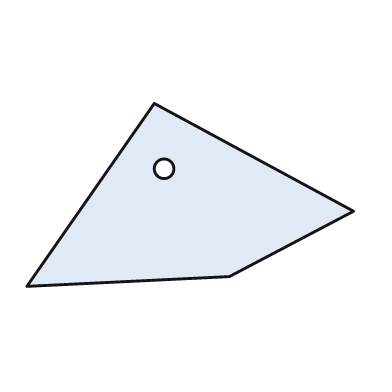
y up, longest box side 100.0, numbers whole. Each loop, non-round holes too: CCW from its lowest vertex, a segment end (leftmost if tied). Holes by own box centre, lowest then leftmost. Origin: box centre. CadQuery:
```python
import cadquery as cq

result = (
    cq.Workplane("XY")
    .moveTo(-50.0, -28.0)
    .lineTo(12.0, -25.0)
    .lineTo(50.0, -5.0)
    .lineTo(-11.0, 28.0)
    .close()
    .moveTo(-8.0, 8.0)
    .circle(3.0)
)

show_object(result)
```